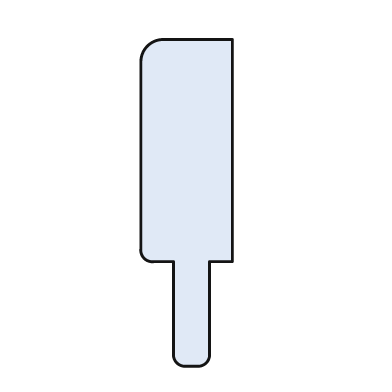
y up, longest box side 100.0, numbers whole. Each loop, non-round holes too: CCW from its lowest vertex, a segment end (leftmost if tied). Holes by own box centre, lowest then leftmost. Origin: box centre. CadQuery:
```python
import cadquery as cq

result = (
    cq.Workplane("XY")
    .moveTo(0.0, -50.0)
    .lineTo(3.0, -50.0)
    .threePointArc((6.0, -49.0), (7.0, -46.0))
    .lineTo(7.0, -18.0)
    .lineTo(14.0, -18.0)
    .lineTo(14.0, 50.0)
    .lineTo(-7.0, 50.0)
    .threePointArc((-12.0, 48.0), (-14.0, 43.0))
    .lineTo(-14.0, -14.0)
    .threePointArc((-13.0, -17.0), (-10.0, -18.0))
    .lineTo(-4.0, -18.0)
    .lineTo(-4.0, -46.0)
    .threePointArc((-3.0, -49.0), (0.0, -50.0))
    .close()
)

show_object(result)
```